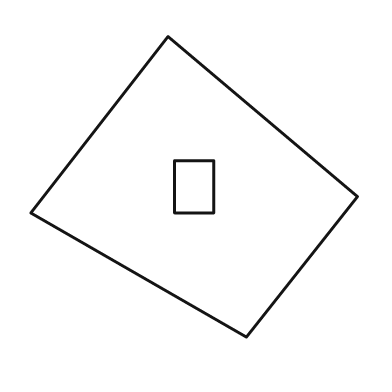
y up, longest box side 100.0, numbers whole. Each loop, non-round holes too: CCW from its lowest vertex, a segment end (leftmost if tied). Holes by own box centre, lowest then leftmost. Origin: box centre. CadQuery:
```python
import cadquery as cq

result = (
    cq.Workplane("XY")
    .moveTo(16.0, -46.0)
    .lineTo(50.0, -3.0)
    .lineTo(-8.0, 46.0)
    .lineTo(-50.0, -8.0)
    .close()
    .moveTo(-6.0, -8.0)
    .lineTo(6.0, -8.0)
    .lineTo(6.0, 8.0)
    .lineTo(-6.0, 8.0)
    .close()
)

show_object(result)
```